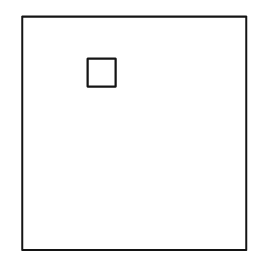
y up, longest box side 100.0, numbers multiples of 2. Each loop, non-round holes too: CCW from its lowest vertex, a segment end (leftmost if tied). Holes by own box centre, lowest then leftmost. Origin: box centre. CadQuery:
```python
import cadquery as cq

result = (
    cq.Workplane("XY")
    .moveTo(-48.0, -50.0)
    .lineTo(48.0, -50.0)
    .lineTo(48.0, 50.0)
    .lineTo(-48.0, 50.0)
    .close()
    .moveTo(-20.0, 20.0)
    .lineTo(-8.0, 20.0)
    .lineTo(-8.0, 32.0)
    .lineTo(-20.0, 32.0)
    .close()
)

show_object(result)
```